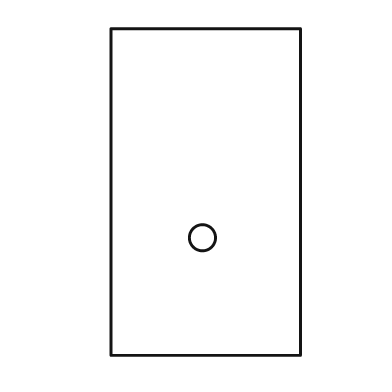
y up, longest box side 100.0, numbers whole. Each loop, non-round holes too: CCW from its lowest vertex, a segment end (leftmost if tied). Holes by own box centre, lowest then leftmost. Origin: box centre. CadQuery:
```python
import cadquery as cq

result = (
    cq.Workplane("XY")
    .moveTo(-29.0, -50.0)
    .lineTo(29.0, -50.0)
    .lineTo(29.0, 50.0)
    .lineTo(-29.0, 50.0)
    .close()
    .moveTo(-1.0, -14.0)
    .circle(4.0)
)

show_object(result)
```